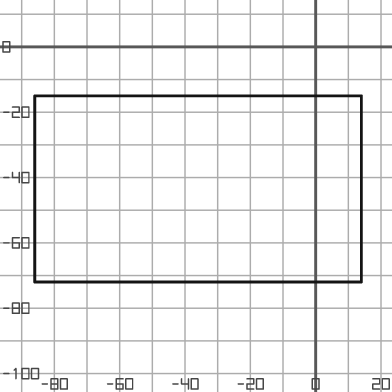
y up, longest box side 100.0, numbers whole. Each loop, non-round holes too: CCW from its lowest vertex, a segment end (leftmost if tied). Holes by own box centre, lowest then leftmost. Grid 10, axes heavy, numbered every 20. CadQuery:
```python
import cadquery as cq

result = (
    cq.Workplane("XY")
    .moveTo(-86.0, -72.0)
    .lineTo(14.0, -72.0)
    .lineTo(14.0, -15.0)
    .lineTo(-86.0, -15.0)
    .close()
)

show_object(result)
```